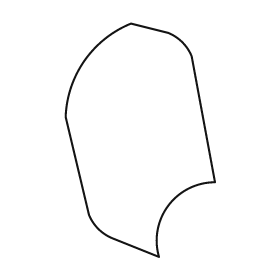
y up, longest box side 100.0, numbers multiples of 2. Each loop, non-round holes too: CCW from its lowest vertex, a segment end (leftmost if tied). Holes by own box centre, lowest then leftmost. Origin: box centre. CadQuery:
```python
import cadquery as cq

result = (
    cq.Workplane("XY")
    .moveTo(8.0, -50.0)
    .threePointArc((12.0, -28.0), (32.0, -18.0))
    .lineTo(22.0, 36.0)
    .threePointArc((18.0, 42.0), (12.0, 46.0))
    .lineTo(-4.0, 50.0)
    .threePointArc((-24.0, 34.0), (-32.0, 10.0))
    .lineTo(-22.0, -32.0)
    .threePointArc((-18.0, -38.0), (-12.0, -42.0))
    .close()
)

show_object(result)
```